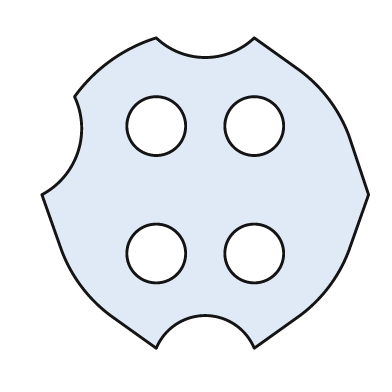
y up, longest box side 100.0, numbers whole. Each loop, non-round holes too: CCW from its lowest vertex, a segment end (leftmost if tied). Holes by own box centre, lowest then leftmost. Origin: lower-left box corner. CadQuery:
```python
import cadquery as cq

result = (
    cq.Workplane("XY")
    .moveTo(35.0, 0.0)
    .threePointArc((50.0, 10.0), (65.0, 0.0))
    .lineTo(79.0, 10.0)
    .threePointArc((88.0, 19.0), (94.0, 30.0))
    .lineTo(100.0, 47.0)
    .lineTo(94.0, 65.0)
    .threePointArc((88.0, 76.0), (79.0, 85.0))
    .lineTo(65.0, 95.0)
    .threePointArc((50.0, 89.0), (35.0, 95.0))
    .threePointArc((21.0, 88.0), (10.0, 77.0))
    .threePointArc((11.0, 60.0), (0.0, 47.0))
    .lineTo(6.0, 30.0)
    .threePointArc((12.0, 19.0), (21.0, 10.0))
    .close()
    .moveTo(35.0, 29.0)
    .circle(9.0)
    .moveTo(65.0, 29.0)
    .circle(9.0)
    .moveTo(35.0, 68.0)
    .circle(9.0)
    .moveTo(65.0, 68.0)
    .circle(9.0)
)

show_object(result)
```